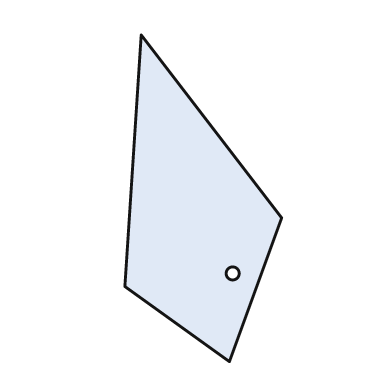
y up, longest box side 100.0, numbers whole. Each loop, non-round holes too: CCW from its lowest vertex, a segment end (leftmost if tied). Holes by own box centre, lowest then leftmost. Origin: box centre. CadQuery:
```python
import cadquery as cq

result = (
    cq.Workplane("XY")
    .moveTo(8.0, -50.0)
    .lineTo(24.0, -6.0)
    .lineTo(-19.0, 50.0)
    .lineTo(-24.0, -27.0)
    .close()
    .moveTo(9.0, -23.0)
    .circle(2.0)
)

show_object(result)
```